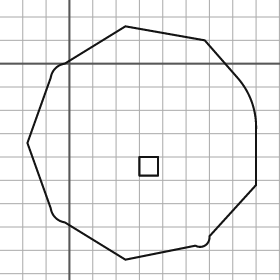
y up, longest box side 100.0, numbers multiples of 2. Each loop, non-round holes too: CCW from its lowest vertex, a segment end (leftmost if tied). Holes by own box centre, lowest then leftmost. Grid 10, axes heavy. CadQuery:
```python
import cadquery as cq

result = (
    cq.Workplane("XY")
    .moveTo(24.0, -84.0)
    .lineTo(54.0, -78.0)
    .threePointArc((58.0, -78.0), (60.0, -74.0))
    .lineTo(80.0, -52.0)
    .lineTo(80.0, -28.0)
    .threePointArc((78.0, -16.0), (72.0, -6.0))
    .lineTo(58.0, 10.0)
    .lineTo(24.0, 16.0)
    .lineTo(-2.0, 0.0)
    .threePointArc((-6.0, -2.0), (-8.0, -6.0))
    .lineTo(-18.0, -34.0)
    .lineTo(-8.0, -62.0)
    .threePointArc((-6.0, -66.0), (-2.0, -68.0))
    .close()
    .moveTo(30.0, -48.0)
    .lineTo(38.0, -48.0)
    .lineTo(38.0, -40.0)
    .lineTo(30.0, -40.0)
    .close()
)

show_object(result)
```